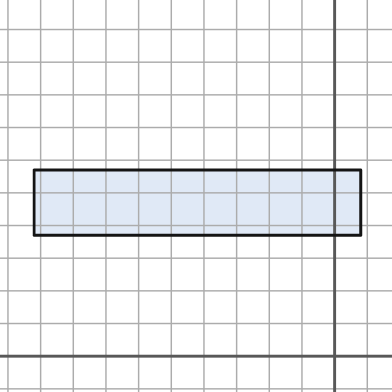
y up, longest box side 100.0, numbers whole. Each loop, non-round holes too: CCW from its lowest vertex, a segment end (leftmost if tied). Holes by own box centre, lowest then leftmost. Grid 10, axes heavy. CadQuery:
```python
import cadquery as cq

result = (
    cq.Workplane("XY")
    .moveTo(-92.0, 37.0)
    .lineTo(8.0, 37.0)
    .lineTo(8.0, 57.0)
    .lineTo(-92.0, 57.0)
    .close()
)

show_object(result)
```